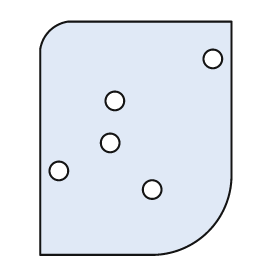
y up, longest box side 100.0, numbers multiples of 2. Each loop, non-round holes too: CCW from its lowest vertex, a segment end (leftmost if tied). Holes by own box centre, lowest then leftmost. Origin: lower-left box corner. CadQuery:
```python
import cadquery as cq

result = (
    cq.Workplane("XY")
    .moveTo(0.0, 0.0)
    .lineTo(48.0, 0.0)
    .threePointArc((72.0, 10.0), (82.0, 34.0))
    .lineTo(82.0, 100.0)
    .lineTo(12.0, 100.0)
    .threePointArc((4.0, 96.0), (0.0, 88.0))
    .close()
    .moveTo(48.0, 28.0)
    .circle(4.0)
    .moveTo(8.0, 36.0)
    .circle(4.0)
    .moveTo(30.0, 48.0)
    .circle(4.0)
    .moveTo(32.0, 66.0)
    .circle(4.0)
    .moveTo(74.0, 84.0)
    .circle(4.0)
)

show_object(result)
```